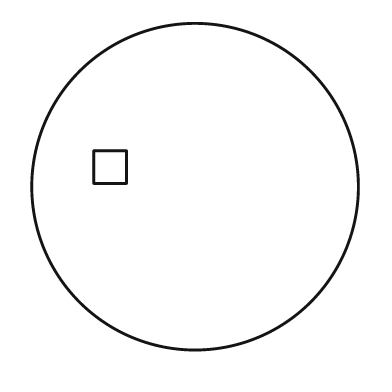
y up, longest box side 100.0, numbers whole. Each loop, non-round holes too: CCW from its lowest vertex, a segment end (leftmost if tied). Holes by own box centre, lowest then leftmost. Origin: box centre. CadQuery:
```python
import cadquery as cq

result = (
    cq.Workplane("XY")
    .moveTo(0.0, 0.0)
    .circle(50.0)
    .moveTo(-31.0, 1.0)
    .lineTo(-21.0, 1.0)
    .lineTo(-21.0, 11.0)
    .lineTo(-31.0, 11.0)
    .close()
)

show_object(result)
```